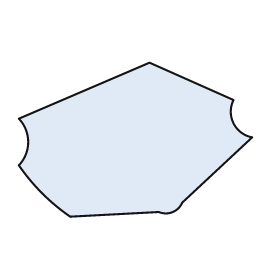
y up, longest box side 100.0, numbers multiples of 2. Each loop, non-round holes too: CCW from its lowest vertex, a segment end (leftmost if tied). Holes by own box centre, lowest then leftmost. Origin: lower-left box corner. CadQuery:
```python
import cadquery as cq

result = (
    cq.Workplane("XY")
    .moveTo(22.0, 0.0)
    .lineTo(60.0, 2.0)
    .threePointArc((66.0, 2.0), (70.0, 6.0))
    .lineTo(100.0, 34.0)
    .threePointArc((92.0, 40.0), (92.0, 50.0))
    .lineTo(56.0, 66.0)
    .lineTo(0.0, 42.0)
    .threePointArc((4.0, 32.0), (0.0, 22.0))
    .threePointArc((10.0, 10.0), (22.0, 0.0))
    .close()
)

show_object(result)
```